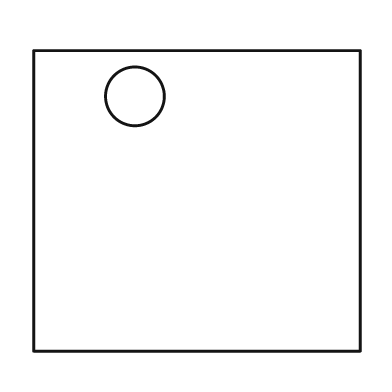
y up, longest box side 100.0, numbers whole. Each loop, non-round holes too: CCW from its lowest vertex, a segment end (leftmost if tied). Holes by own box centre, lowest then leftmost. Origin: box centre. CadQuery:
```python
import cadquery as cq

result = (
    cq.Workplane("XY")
    .moveTo(-50.0, -46.0)
    .lineTo(50.0, -46.0)
    .lineTo(50.0, 46.0)
    .lineTo(-50.0, 46.0)
    .close()
    .moveTo(-19.0, 32.0)
    .circle(9.0)
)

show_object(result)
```